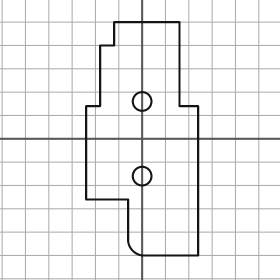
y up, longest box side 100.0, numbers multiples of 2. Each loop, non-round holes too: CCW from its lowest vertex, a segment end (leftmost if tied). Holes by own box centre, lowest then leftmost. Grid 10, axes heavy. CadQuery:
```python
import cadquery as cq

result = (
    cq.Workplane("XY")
    .moveTo(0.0, -50.0)
    .lineTo(24.0, -50.0)
    .lineTo(24.0, 14.0)
    .lineTo(16.0, 14.0)
    .lineTo(16.0, 50.0)
    .lineTo(-12.0, 50.0)
    .lineTo(-12.0, 40.0)
    .lineTo(-18.0, 40.0)
    .lineTo(-18.0, 14.0)
    .lineTo(-24.0, 14.0)
    .lineTo(-24.0, -26.0)
    .lineTo(-6.0, -26.0)
    .lineTo(-6.0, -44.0)
    .threePointArc((-4.0, -48.0), (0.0, -50.0))
    .close()
    .moveTo(0.0, -16.0)
    .circle(4.0)
    .moveTo(0.0, 16.0)
    .circle(4.0)
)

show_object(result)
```